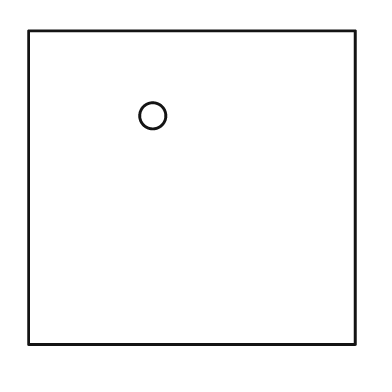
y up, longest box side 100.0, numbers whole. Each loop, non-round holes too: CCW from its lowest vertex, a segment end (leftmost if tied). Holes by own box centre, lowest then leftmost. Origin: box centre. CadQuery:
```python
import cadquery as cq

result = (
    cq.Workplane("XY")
    .moveTo(-50.0, -48.0)
    .lineTo(50.0, -48.0)
    .lineTo(50.0, 48.0)
    .lineTo(-50.0, 48.0)
    .close()
    .moveTo(-12.0, 22.0)
    .circle(4.0)
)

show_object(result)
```